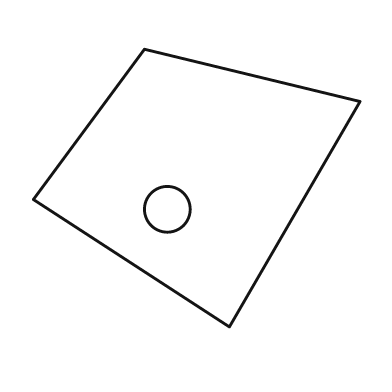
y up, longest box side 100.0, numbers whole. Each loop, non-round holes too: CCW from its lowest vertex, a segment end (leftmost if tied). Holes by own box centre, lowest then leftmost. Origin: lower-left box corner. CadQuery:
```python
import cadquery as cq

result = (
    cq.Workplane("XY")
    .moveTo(60.0, 0.0)
    .lineTo(100.0, 69.0)
    .lineTo(34.0, 85.0)
    .lineTo(0.0, 39.0)
    .close()
    .moveTo(41.0, 36.0)
    .circle(7.0)
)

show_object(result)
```